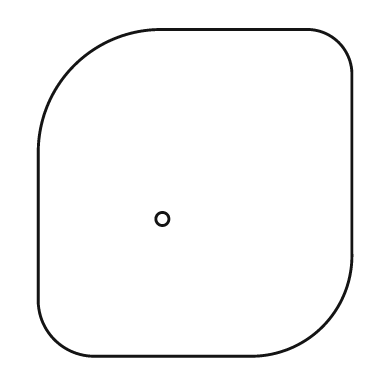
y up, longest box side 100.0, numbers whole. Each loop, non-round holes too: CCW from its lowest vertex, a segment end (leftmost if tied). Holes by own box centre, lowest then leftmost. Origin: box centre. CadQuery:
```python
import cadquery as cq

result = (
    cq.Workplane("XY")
    .moveTo(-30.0, -50.0)
    .lineTo(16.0, -50.0)
    .threePointArc((39.0, -41.0), (48.0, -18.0))
    .lineTo(48.0, 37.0)
    .threePointArc((44.0, 46.0), (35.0, 50.0))
    .lineTo(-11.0, 50.0)
    .threePointArc((-37.0, 39.0), (-48.0, 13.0))
    .lineTo(-48.0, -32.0)
    .threePointArc((-43.0, -45.0), (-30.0, -50.0))
    .close()
    .moveTo(-10.0, -8.0)
    .circle(2.0)
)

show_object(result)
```